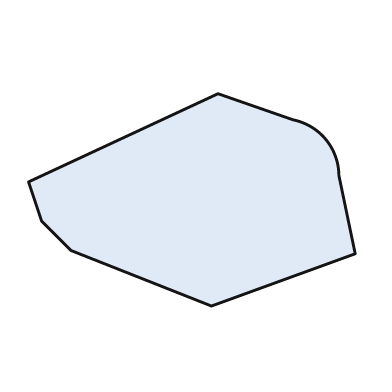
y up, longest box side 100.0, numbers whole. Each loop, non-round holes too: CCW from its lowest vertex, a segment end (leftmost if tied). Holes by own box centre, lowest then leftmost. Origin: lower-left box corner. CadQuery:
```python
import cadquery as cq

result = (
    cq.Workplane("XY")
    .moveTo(56.0, 0.0)
    .lineTo(100.0, 16.0)
    .lineTo(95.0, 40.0)
    .threePointArc((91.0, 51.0), (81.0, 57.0))
    .lineTo(58.0, 65.0)
    .lineTo(0.0, 38.0)
    .lineTo(4.0, 26.0)
    .lineTo(13.0, 17.0)
    .close()
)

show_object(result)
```